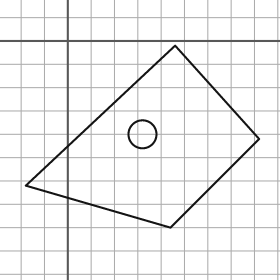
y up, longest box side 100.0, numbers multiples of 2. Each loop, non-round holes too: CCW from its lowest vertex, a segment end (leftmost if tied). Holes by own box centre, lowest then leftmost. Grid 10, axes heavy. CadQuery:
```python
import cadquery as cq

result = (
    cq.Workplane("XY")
    .moveTo(44.0, -80.0)
    .lineTo(82.0, -42.0)
    .lineTo(46.0, -2.0)
    .lineTo(-18.0, -62.0)
    .close()
    .moveTo(32.0, -40.0)
    .circle(6.0)
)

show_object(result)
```